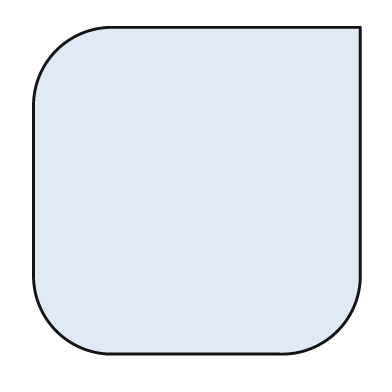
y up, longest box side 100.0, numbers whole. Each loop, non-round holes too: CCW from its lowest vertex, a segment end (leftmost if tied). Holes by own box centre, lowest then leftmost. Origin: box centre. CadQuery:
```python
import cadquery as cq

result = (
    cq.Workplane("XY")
    .moveTo(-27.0, -50.0)
    .lineTo(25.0, -50.0)
    .threePointArc((43.0, -43.0), (50.0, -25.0))
    .lineTo(50.0, 50.0)
    .lineTo(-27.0, 50.0)
    .threePointArc((-43.0, 43.0), (-50.0, 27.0))
    .lineTo(-50.0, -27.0)
    .threePointArc((-43.0, -43.0), (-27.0, -50.0))
    .close()
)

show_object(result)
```